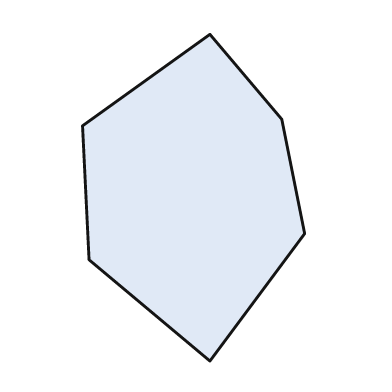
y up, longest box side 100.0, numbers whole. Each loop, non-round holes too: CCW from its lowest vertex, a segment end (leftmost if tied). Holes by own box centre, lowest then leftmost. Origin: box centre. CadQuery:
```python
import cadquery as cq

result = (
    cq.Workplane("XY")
    .moveTo(5.0, -50.0)
    .lineTo(34.0, -11.0)
    .lineTo(27.0, 24.0)
    .lineTo(5.0, 50.0)
    .lineTo(-34.0, 22.0)
    .lineTo(-32.0, -19.0)
    .close()
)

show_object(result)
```